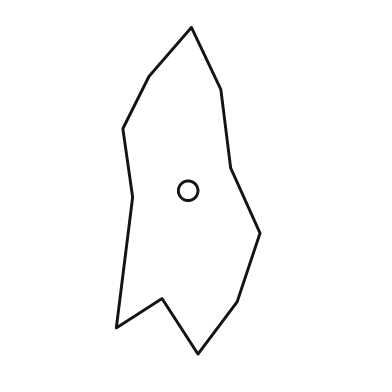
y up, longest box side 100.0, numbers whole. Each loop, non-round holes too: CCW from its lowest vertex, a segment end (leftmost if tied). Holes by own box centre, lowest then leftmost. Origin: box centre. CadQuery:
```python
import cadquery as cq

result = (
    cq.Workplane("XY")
    .moveTo(3.0, -50.0)
    .lineTo(15.0, -34.0)
    .lineTo(22.0, -13.0)
    .lineTo(13.0, 7.0)
    .lineTo(10.0, 31.0)
    .lineTo(1.0, 50.0)
    .lineTo(-12.0, 35.0)
    .lineTo(-20.0, 19.0)
    .lineTo(-17.0, -2.0)
    .lineTo(-22.0, -42.0)
    .lineTo(-8.0, -33.0)
    .close()
    .moveTo(0.0, 0.0)
    .circle(3.0)
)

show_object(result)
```